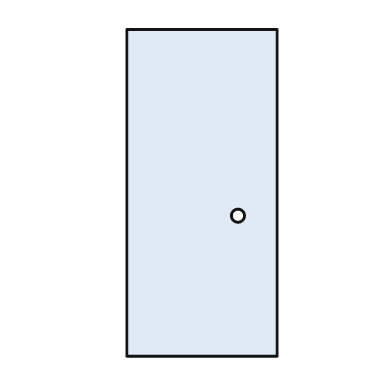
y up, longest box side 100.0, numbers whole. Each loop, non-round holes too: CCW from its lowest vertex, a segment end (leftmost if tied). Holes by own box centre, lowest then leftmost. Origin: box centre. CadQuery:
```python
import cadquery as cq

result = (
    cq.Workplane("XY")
    .moveTo(-23.0, -50.0)
    .lineTo(23.0, -50.0)
    .lineTo(23.0, 50.0)
    .lineTo(-23.0, 50.0)
    .close()
    .moveTo(11.0, -7.0)
    .circle(2.0)
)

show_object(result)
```